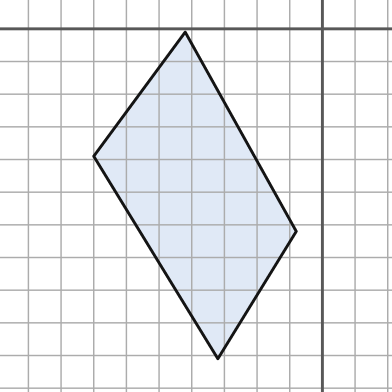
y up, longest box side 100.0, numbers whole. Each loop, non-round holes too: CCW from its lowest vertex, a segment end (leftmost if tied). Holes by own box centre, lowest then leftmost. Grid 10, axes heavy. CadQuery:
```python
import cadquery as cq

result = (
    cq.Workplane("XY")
    .moveTo(-32.0, -101.0)
    .lineTo(-8.0, -62.0)
    .lineTo(-42.0, -1.0)
    .lineTo(-70.0, -39.0)
    .close()
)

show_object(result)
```